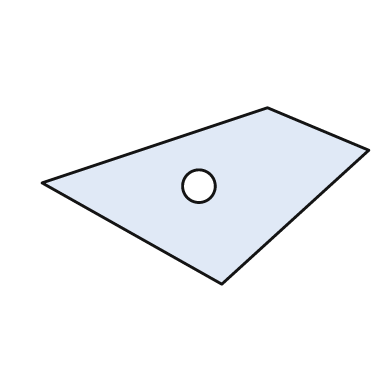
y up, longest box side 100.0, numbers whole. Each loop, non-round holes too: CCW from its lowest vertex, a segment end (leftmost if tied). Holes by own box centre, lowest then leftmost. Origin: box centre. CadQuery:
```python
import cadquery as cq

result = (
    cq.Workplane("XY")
    .moveTo(5.0, -27.0)
    .lineTo(50.0, 14.0)
    .lineTo(19.0, 27.0)
    .lineTo(-50.0, 4.0)
    .close()
    .moveTo(-2.0, 3.0)
    .circle(5.0)
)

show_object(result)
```